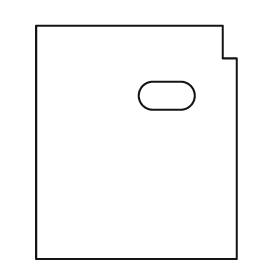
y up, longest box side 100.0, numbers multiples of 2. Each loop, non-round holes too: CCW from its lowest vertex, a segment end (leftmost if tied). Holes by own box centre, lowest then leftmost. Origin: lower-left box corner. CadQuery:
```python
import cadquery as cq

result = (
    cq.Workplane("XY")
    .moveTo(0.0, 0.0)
    .lineTo(86.0, 0.0)
    .lineTo(86.0, 86.0)
    .lineTo(80.0, 86.0)
    .lineTo(80.0, 100.0)
    .lineTo(0.0, 100.0)
    .close()
    .moveTo(50.0, 64.0)
    .lineTo(62.0, 64.0)
    .threePointArc((68.0, 70.0), (62.0, 76.0))
    .lineTo(50.0, 76.0)
    .threePointArc((44.0, 70.0), (50.0, 64.0))
    .close()
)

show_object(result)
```